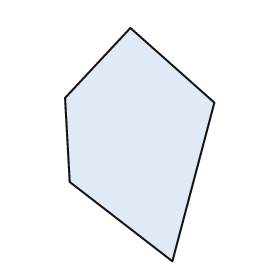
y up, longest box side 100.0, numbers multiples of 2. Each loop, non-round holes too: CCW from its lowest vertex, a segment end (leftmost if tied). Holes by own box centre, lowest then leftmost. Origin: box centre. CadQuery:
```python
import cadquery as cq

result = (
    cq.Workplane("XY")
    .moveTo(14.0, -50.0)
    .lineTo(32.0, 18.0)
    .lineTo(-4.0, 50.0)
    .lineTo(-32.0, 20.0)
    .lineTo(-30.0, -16.0)
    .close()
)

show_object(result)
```